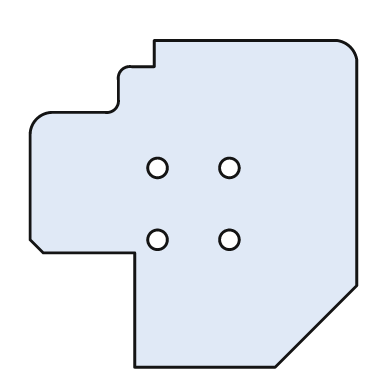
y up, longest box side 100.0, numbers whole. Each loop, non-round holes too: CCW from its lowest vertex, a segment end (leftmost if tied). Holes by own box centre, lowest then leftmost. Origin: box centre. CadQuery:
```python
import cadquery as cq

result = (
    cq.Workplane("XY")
    .moveTo(-18.0, -50.0)
    .lineTo(25.0, -50.0)
    .lineTo(50.0, -25.0)
    .lineTo(50.0, 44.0)
    .threePointArc((48.0, 48.0), (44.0, 50.0))
    .lineTo(-12.0, 50.0)
    .lineTo(-12.0, 42.0)
    .lineTo(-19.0, 42.0)
    .threePointArc((-22.0, 41.0), (-23.0, 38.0))
    .lineTo(-23.0, 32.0)
    .threePointArc((-24.0, 29.0), (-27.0, 28.0))
    .lineTo(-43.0, 28.0)
    .threePointArc((-48.0, 26.0), (-50.0, 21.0))
    .lineTo(-50.0, -11.0)
    .lineTo(-46.0, -15.0)
    .lineTo(-18.0, -15.0)
    .close()
    .moveTo(-11.0, -11.0)
    .circle(3.0)
    .moveTo(11.0, -11.0)
    .circle(3.0)
    .moveTo(-11.0, 11.0)
    .circle(3.0)
    .moveTo(11.0, 11.0)
    .circle(3.0)
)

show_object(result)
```